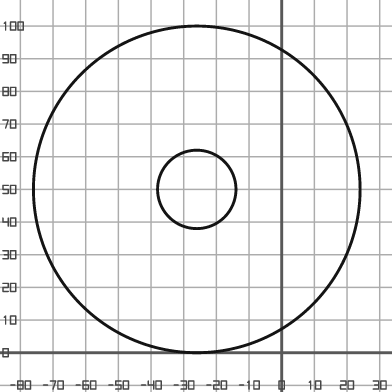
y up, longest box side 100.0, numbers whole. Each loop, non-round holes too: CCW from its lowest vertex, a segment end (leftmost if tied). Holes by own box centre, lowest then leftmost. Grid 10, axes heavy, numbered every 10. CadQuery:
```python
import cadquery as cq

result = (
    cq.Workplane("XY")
    .moveTo(-26.0, 50.0)
    .circle(50.0)
    .moveTo(-26.0, 50.0)
    .circle(12.0)
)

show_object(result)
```